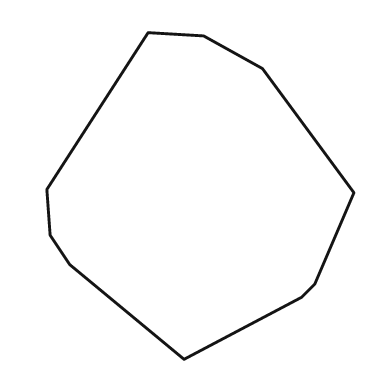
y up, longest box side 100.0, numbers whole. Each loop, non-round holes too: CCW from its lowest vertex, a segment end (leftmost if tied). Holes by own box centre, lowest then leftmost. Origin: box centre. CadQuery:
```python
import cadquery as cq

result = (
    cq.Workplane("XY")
    .moveTo(-5.0, -50.0)
    .lineTo(31.0, -31.0)
    .lineTo(35.0, -27.0)
    .lineTo(47.0, 1.0)
    .lineTo(19.0, 39.0)
    .lineTo(1.0, 49.0)
    .lineTo(-16.0, 50.0)
    .lineTo(-47.0, 2.0)
    .lineTo(-46.0, -12.0)
    .lineTo(-40.0, -21.0)
    .close()
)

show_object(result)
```